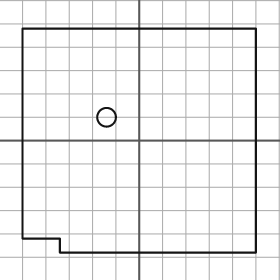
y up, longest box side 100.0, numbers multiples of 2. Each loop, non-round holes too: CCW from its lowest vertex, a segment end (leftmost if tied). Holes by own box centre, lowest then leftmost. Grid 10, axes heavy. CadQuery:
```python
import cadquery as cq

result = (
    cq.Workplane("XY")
    .moveTo(-34.0, -48.0)
    .lineTo(50.0, -48.0)
    .lineTo(50.0, 48.0)
    .lineTo(-50.0, 48.0)
    .lineTo(-50.0, -42.0)
    .lineTo(-34.0, -42.0)
    .close()
    .moveTo(-14.0, 10.0)
    .circle(4.0)
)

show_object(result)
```